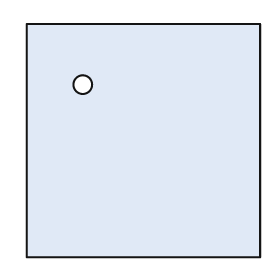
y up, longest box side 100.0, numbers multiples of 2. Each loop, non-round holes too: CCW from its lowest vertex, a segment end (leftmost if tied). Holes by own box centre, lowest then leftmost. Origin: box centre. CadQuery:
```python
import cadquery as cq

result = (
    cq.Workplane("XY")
    .moveTo(-50.0, -50.0)
    .lineTo(50.0, -50.0)
    .lineTo(50.0, 50.0)
    .lineTo(-50.0, 50.0)
    .close()
    .moveTo(-26.0, 24.0)
    .circle(4.0)
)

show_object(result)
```